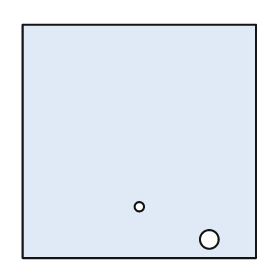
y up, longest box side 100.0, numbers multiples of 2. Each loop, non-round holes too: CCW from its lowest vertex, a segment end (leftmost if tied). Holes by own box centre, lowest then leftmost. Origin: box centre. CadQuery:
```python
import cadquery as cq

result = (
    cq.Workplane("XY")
    .moveTo(-50.0, -50.0)
    .lineTo(50.0, -50.0)
    .lineTo(50.0, 50.0)
    .lineTo(-50.0, 50.0)
    .close()
    .moveTo(30.0, -42.0)
    .circle(4.0)
    .moveTo(0.0, -28.0)
    .circle(2.0)
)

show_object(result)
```